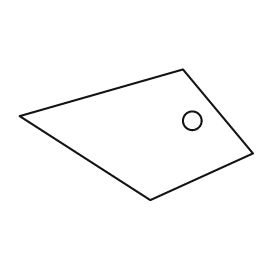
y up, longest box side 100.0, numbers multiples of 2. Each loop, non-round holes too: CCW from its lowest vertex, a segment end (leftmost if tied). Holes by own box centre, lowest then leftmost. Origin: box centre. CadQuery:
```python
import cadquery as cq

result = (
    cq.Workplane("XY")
    .moveTo(6.0, -28.0)
    .lineTo(50.0, -8.0)
    .lineTo(20.0, 28.0)
    .lineTo(-50.0, 8.0)
    .close()
    .moveTo(24.0, 6.0)
    .circle(4.0)
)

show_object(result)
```